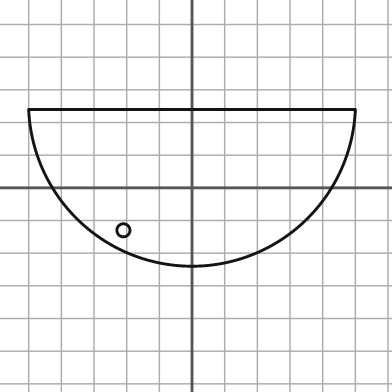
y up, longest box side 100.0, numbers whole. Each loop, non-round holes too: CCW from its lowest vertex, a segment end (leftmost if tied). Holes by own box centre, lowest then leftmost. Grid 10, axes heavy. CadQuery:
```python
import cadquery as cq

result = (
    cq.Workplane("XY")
    .moveTo(-50.0, 24.0)
    .threePointArc((0.0, -24.0), (50.0, 24.0))
    .close()
    .moveTo(-21.0, -13.0)
    .circle(2.0)
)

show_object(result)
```